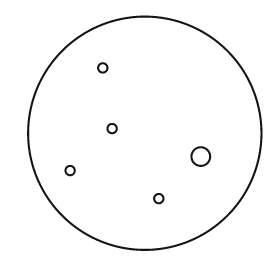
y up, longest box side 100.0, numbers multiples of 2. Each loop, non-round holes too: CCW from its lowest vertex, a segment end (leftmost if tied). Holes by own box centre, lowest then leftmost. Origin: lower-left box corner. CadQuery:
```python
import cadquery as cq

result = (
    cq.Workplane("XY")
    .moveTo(50.0, 50.0)
    .circle(50.0)
    .moveTo(56.0, 22.0)
    .circle(2.0)
    .moveTo(18.0, 34.0)
    .circle(2.0)
    .moveTo(74.0, 40.0)
    .circle(4.0)
    .moveTo(36.0, 52.0)
    .circle(2.0)
    .moveTo(32.0, 78.0)
    .circle(2.0)
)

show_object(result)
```